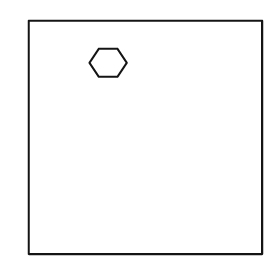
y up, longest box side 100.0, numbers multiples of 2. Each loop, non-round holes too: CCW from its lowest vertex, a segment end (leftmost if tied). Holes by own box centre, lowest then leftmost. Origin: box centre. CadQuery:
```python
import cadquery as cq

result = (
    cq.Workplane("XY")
    .moveTo(-50.0, -50.0)
    .lineTo(50.0, -50.0)
    .lineTo(50.0, 50.0)
    .lineTo(-50.0, 50.0)
    .close()
    .moveTo(-20.0, 26.0)
    .lineTo(-12.0, 26.0)
    .lineTo(-8.0, 32.0)
    .lineTo(-12.0, 38.0)
    .lineTo(-20.0, 38.0)
    .lineTo(-24.0, 32.0)
    .close()
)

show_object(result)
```